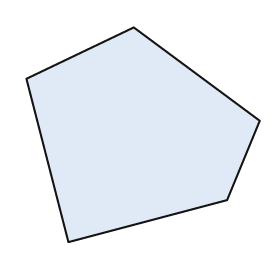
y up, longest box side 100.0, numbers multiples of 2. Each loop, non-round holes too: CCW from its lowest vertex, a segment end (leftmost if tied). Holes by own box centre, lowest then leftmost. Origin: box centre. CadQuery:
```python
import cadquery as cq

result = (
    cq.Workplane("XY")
    .moveTo(-32.0, -46.0)
    .lineTo(36.0, -28.0)
    .lineTo(50.0, 6.0)
    .lineTo(-4.0, 46.0)
    .lineTo(-50.0, 24.0)
    .close()
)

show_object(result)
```